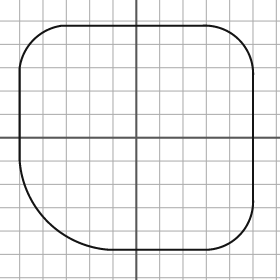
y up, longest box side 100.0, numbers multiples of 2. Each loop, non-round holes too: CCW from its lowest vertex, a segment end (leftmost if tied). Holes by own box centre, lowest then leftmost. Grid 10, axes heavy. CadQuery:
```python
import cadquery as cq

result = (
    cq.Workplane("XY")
    .moveTo(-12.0, -48.0)
    .lineTo(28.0, -48.0)
    .threePointArc((44.0, -42.0), (50.0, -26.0))
    .lineTo(50.0, 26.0)
    .threePointArc((44.0, 42.0), (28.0, 48.0))
    .lineTo(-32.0, 48.0)
    .threePointArc((-44.0, 42.0), (-50.0, 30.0))
    .lineTo(-50.0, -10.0)
    .threePointArc((-38.0, -36.0), (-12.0, -48.0))
    .close()
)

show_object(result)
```